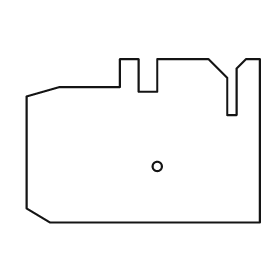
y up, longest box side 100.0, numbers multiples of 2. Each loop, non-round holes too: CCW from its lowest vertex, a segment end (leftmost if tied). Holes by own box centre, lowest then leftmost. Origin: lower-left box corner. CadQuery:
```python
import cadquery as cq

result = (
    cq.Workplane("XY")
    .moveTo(10.0, 0.0)
    .lineTo(100.0, 0.0)
    .lineTo(100.0, 70.0)
    .lineTo(94.0, 70.0)
    .lineTo(90.0, 66.0)
    .lineTo(90.0, 46.0)
    .lineTo(86.0, 46.0)
    .lineTo(86.0, 62.0)
    .lineTo(78.0, 70.0)
    .lineTo(56.0, 70.0)
    .lineTo(56.0, 56.0)
    .lineTo(48.0, 56.0)
    .lineTo(48.0, 70.0)
    .lineTo(40.0, 70.0)
    .lineTo(40.0, 58.0)
    .lineTo(14.0, 58.0)
    .lineTo(0.0, 54.0)
    .lineTo(0.0, 6.0)
    .close()
    .moveTo(56.0, 24.0)
    .circle(2.0)
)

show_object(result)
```